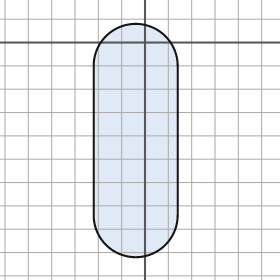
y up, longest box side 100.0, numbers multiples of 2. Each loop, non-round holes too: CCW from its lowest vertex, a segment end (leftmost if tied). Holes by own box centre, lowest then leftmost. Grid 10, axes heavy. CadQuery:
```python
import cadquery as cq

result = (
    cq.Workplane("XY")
    .moveTo(-22.0, -74.0)
    .threePointArc((-4.0, -92.0), (14.0, -74.0))
    .lineTo(14.0, -10.0)
    .threePointArc((-4.0, 8.0), (-22.0, -10.0))
    .close()
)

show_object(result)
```